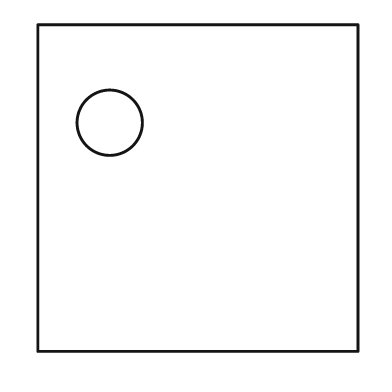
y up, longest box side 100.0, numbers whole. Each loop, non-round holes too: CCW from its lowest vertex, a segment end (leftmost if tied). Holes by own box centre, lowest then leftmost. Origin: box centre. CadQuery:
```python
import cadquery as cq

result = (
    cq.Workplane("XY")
    .moveTo(-49.0, -50.0)
    .lineTo(49.0, -50.0)
    .lineTo(49.0, 50.0)
    .lineTo(-49.0, 50.0)
    .close()
    .moveTo(-27.0, 20.0)
    .circle(10.0)
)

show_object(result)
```